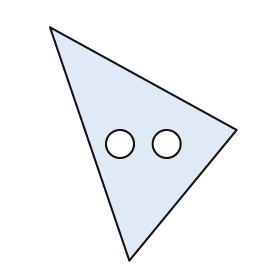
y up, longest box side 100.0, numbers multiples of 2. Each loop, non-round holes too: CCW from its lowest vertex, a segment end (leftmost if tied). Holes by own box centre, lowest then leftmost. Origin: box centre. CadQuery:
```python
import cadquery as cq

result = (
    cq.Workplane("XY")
    .moveTo(-6.0, -50.0)
    .lineTo(40.0, 6.0)
    .lineTo(-40.0, 50.0)
    .close()
    .moveTo(-10.0, 0.0)
    .circle(6.0)
    .moveTo(10.0, 0.0)
    .circle(6.0)
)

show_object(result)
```